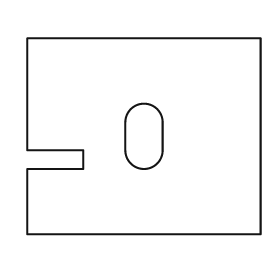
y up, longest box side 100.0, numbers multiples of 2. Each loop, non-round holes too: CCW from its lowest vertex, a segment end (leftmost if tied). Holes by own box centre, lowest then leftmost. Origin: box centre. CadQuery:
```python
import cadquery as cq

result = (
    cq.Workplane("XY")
    .moveTo(-50.0, -42.0)
    .lineTo(50.0, -42.0)
    .lineTo(50.0, 42.0)
    .lineTo(-50.0, 42.0)
    .lineTo(-50.0, -6.0)
    .lineTo(-26.0, -6.0)
    .lineTo(-26.0, -14.0)
    .lineTo(-50.0, -14.0)
    .close()
    .moveTo(-8.0, -6.0)
    .threePointArc((0.0, -14.0), (8.0, -6.0))
    .lineTo(8.0, 6.0)
    .threePointArc((0.0, 14.0), (-8.0, 6.0))
    .close()
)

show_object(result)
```